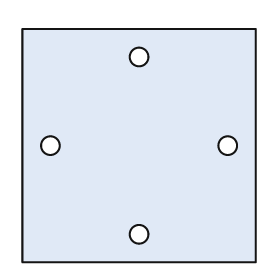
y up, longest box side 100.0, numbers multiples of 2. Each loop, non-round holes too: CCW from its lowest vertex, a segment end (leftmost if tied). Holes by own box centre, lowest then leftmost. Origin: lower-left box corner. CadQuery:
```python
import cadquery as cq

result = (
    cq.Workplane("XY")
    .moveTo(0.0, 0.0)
    .lineTo(100.0, 0.0)
    .lineTo(100.0, 100.0)
    .lineTo(0.0, 100.0)
    .close()
    .moveTo(50.0, 12.0)
    .circle(4.0)
    .moveTo(12.0, 50.0)
    .circle(4.0)
    .moveTo(88.0, 50.0)
    .circle(4.0)
    .moveTo(50.0, 88.0)
    .circle(4.0)
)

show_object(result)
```